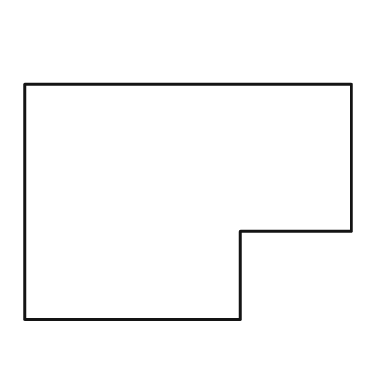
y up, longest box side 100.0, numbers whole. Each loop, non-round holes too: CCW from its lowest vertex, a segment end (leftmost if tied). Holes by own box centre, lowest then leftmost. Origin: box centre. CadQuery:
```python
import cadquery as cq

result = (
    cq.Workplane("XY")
    .moveTo(-50.0, -36.0)
    .lineTo(16.0, -36.0)
    .lineTo(16.0, -9.0)
    .lineTo(50.0, -9.0)
    .lineTo(50.0, 36.0)
    .lineTo(-50.0, 36.0)
    .close()
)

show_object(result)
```